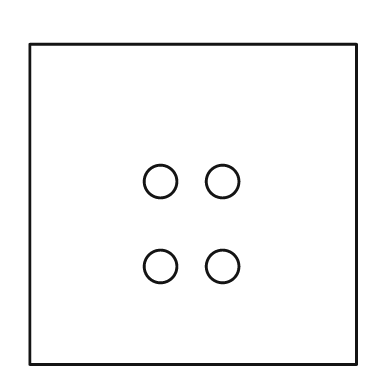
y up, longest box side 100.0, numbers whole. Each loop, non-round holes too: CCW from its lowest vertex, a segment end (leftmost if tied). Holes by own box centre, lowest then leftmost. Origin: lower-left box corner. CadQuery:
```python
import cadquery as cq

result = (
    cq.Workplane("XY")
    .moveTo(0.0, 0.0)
    .lineTo(100.0, 0.0)
    .lineTo(100.0, 98.0)
    .lineTo(0.0, 98.0)
    .close()
    .moveTo(40.0, 30.0)
    .circle(5.0)
    .moveTo(59.0, 30.0)
    .circle(5.0)
    .moveTo(40.0, 56.0)
    .circle(5.0)
    .moveTo(59.0, 56.0)
    .circle(5.0)
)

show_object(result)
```